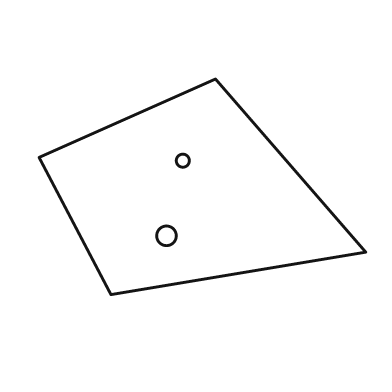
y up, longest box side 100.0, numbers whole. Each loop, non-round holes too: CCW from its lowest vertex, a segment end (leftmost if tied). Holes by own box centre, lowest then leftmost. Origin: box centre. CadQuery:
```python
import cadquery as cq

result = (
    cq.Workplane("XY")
    .moveTo(-28.0, -33.0)
    .lineTo(50.0, -20.0)
    .lineTo(4.0, 33.0)
    .lineTo(-50.0, 9.0)
    .close()
    .moveTo(-11.0, -15.0)
    .circle(3.0)
    .moveTo(-6.0, 8.0)
    .circle(2.0)
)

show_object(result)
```